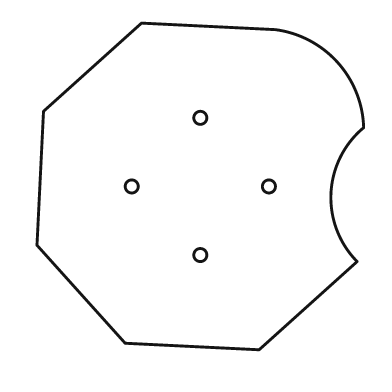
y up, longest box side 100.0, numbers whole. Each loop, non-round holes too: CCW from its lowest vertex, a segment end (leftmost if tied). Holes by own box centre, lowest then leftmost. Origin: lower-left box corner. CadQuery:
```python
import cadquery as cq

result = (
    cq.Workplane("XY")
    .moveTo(68.0, 0.0)
    .lineTo(98.0, 27.0)
    .threePointArc((90.0, 48.0), (100.0, 68.0))
    .threePointArc((92.0, 88.0), (73.0, 98.0))
    .lineTo(32.0, 100.0)
    .lineTo(2.0, 73.0)
    .lineTo(0.0, 32.0)
    .lineTo(27.0, 2.0)
    .close()
    .moveTo(50.0, 29.0)
    .circle(2.0)
    .moveTo(29.0, 50.0)
    .circle(2.0)
    .moveTo(71.0, 50.0)
    .circle(2.0)
    .moveTo(50.0, 71.0)
    .circle(2.0)
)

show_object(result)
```